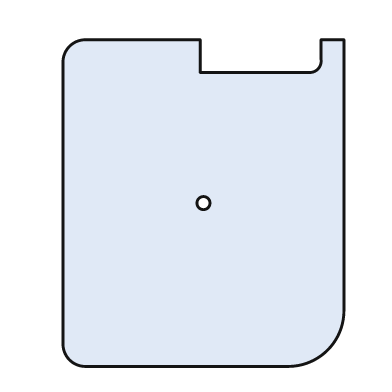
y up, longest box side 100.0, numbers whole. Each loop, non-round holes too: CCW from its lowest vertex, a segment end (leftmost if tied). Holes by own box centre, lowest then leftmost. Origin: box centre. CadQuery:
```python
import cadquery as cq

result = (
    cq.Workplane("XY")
    .moveTo(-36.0, -50.0)
    .lineTo(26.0, -50.0)
    .threePointArc((38.0, -45.0), (43.0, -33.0))
    .lineTo(43.0, 50.0)
    .lineTo(36.0, 50.0)
    .lineTo(36.0, 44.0)
    .threePointArc((35.0, 41.0), (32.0, 40.0))
    .lineTo(-1.0, 40.0)
    .lineTo(-1.0, 50.0)
    .lineTo(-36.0, 50.0)
    .threePointArc((-41.0, 48.0), (-43.0, 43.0))
    .lineTo(-43.0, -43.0)
    .threePointArc((-41.0, -48.0), (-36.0, -50.0))
    .close()
    .moveTo(0.0, 0.0)
    .circle(2.0)
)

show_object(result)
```